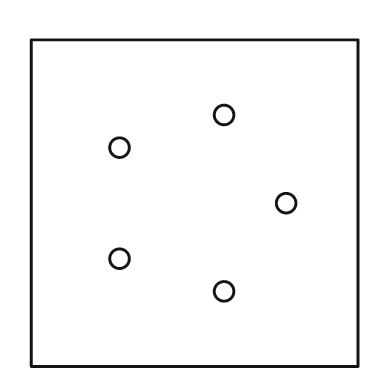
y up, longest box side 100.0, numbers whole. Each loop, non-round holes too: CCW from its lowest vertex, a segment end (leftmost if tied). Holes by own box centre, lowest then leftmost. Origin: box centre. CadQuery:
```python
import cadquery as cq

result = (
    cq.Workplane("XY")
    .moveTo(-50.0, -50.0)
    .lineTo(50.0, -50.0)
    .lineTo(50.0, 50.0)
    .lineTo(-50.0, 50.0)
    .close()
    .moveTo(9.0, -27.0)
    .circle(3.0)
    .moveTo(-23.0, -17.0)
    .circle(3.0)
    .moveTo(28.0, 0.0)
    .circle(3.0)
    .moveTo(-23.0, 17.0)
    .circle(3.0)
    .moveTo(9.0, 27.0)
    .circle(3.0)
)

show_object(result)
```